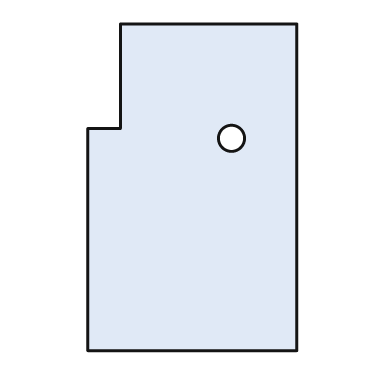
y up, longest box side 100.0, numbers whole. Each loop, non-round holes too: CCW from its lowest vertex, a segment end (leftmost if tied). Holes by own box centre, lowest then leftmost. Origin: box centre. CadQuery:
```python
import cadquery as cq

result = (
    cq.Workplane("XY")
    .moveTo(-32.0, -50.0)
    .lineTo(32.0, -50.0)
    .lineTo(32.0, 50.0)
    .lineTo(-22.0, 50.0)
    .lineTo(-22.0, 18.0)
    .lineTo(-32.0, 18.0)
    .close()
    .moveTo(12.0, 15.0)
    .circle(4.0)
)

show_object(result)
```